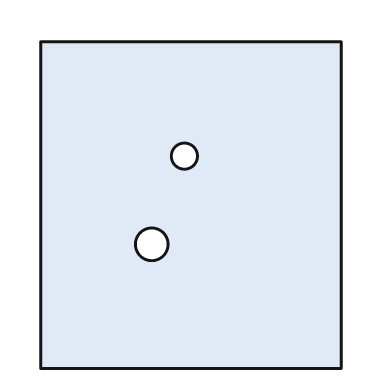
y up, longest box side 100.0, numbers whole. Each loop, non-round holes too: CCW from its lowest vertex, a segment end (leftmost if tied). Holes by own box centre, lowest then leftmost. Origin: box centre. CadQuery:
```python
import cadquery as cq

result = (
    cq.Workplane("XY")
    .moveTo(-46.0, -50.0)
    .lineTo(46.0, -50.0)
    .lineTo(46.0, 50.0)
    .lineTo(-46.0, 50.0)
    .close()
    .moveTo(-12.0, -12.0)
    .circle(5.0)
    .moveTo(-2.0, 15.0)
    .circle(4.0)
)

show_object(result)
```